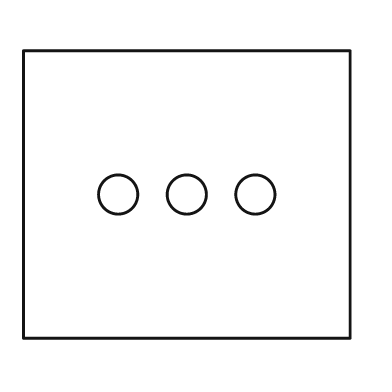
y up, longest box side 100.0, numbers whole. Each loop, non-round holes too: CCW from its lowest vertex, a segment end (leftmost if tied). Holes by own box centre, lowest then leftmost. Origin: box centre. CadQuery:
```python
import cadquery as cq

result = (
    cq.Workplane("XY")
    .moveTo(-50.0, -44.0)
    .lineTo(50.0, -44.0)
    .lineTo(50.0, 44.0)
    .lineTo(-50.0, 44.0)
    .close()
    .moveTo(-21.0, 0.0)
    .circle(6.0)
    .moveTo(0.0, 0.0)
    .circle(6.0)
    .moveTo(21.0, 0.0)
    .circle(6.0)
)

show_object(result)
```